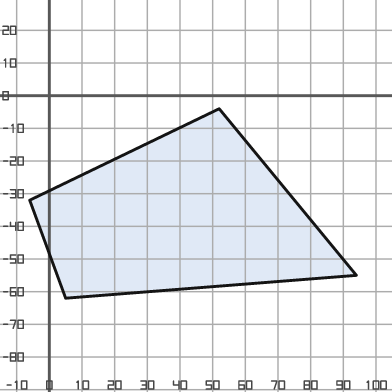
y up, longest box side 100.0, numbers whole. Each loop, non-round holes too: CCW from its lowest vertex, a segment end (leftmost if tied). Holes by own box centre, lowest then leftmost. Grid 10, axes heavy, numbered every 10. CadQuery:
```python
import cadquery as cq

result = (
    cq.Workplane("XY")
    .moveTo(5.0, -62.0)
    .lineTo(94.0, -55.0)
    .lineTo(52.0, -4.0)
    .lineTo(-6.0, -32.0)
    .close()
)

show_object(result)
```